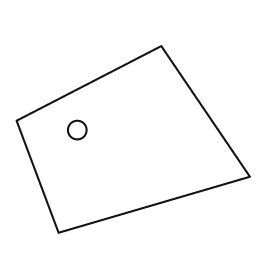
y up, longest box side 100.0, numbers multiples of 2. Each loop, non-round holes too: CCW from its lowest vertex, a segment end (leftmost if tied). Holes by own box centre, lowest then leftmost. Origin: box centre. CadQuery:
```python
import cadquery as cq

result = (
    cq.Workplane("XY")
    .moveTo(-32.0, -40.0)
    .lineTo(50.0, -16.0)
    .lineTo(12.0, 40.0)
    .lineTo(-50.0, 8.0)
    .close()
    .moveTo(-24.0, 4.0)
    .circle(4.0)
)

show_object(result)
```